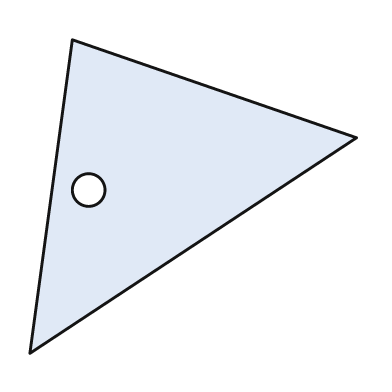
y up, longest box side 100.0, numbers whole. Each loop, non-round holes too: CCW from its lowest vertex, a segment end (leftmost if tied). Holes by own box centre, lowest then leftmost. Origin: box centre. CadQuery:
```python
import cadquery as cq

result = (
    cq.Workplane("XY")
    .moveTo(-50.0, -48.0)
    .lineTo(50.0, 18.0)
    .lineTo(-37.0, 48.0)
    .close()
    .moveTo(-32.0, 2.0)
    .circle(5.0)
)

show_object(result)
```